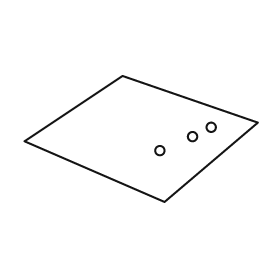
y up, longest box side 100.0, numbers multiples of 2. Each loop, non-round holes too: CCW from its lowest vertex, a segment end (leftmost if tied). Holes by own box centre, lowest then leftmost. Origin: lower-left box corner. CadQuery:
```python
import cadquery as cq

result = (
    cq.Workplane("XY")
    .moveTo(60.0, 0.0)
    .lineTo(100.0, 34.0)
    .lineTo(42.0, 54.0)
    .lineTo(0.0, 26.0)
    .close()
    .moveTo(58.0, 22.0)
    .circle(2.0)
    .moveTo(72.0, 28.0)
    .circle(2.0)
    .moveTo(80.0, 32.0)
    .circle(2.0)
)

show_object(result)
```